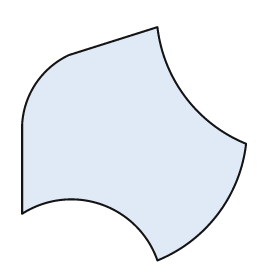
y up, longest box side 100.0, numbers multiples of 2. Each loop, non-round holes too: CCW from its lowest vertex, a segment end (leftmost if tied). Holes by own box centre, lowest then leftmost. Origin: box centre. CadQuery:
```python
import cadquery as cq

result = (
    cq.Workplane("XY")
    .moveTo(10.0, -50.0)
    .threePointArc((36.0, -30.0), (48.0, 0.0))
    .threePointArc((22.0, 20.0), (10.0, 50.0))
    .lineTo(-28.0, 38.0)
    .threePointArc((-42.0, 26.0), (-48.0, 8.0))
    .lineTo(-48.0, -30.0)
    .threePointArc((-14.0, -26.0), (10.0, -50.0))
    .close()
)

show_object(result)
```